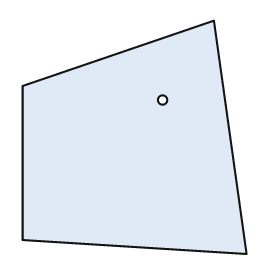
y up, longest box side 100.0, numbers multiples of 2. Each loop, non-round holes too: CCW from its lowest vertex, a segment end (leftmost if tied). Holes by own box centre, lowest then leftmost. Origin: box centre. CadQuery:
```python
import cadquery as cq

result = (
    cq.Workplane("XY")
    .moveTo(48.0, -50.0)
    .lineTo(34.0, 50.0)
    .lineTo(-48.0, 22.0)
    .lineTo(-48.0, -44.0)
    .close()
    .moveTo(12.0, 16.0)
    .circle(2.0)
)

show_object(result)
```